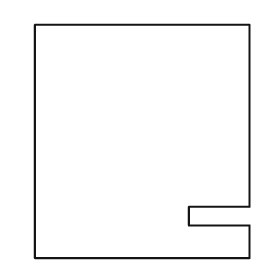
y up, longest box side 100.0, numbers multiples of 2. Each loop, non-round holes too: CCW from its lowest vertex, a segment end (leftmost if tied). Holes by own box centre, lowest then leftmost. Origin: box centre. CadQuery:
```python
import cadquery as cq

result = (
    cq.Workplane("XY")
    .moveTo(-46.0, -50.0)
    .lineTo(46.0, -50.0)
    .lineTo(46.0, -36.0)
    .lineTo(20.0, -36.0)
    .lineTo(20.0, -28.0)
    .lineTo(46.0, -28.0)
    .lineTo(46.0, 50.0)
    .lineTo(-46.0, 50.0)
    .close()
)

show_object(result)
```